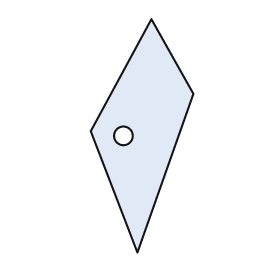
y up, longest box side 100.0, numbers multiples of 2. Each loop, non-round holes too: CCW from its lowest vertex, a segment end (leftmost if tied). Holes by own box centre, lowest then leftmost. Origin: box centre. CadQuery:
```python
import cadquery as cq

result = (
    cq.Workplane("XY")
    .moveTo(-2.0, -50.0)
    .lineTo(22.0, 18.0)
    .lineTo(4.0, 50.0)
    .lineTo(-22.0, 2.0)
    .close()
    .moveTo(-8.0, 0.0)
    .circle(4.0)
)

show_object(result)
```